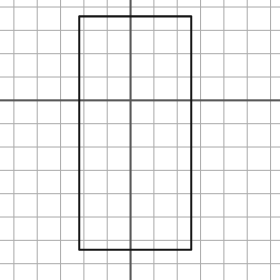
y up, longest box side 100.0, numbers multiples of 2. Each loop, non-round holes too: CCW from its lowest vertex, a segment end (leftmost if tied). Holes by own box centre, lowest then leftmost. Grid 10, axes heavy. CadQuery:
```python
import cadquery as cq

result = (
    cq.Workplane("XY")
    .moveTo(-22.0, -64.0)
    .lineTo(26.0, -64.0)
    .lineTo(26.0, 36.0)
    .lineTo(-22.0, 36.0)
    .close()
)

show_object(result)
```